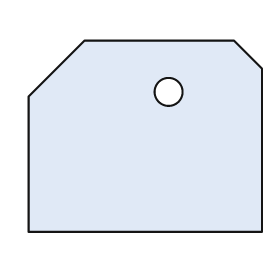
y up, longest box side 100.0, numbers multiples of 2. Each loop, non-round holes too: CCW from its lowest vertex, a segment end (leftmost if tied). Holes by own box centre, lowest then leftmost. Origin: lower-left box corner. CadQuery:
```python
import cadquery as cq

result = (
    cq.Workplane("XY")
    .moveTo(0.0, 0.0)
    .lineTo(100.0, 0.0)
    .lineTo(100.0, 70.0)
    .lineTo(88.0, 82.0)
    .lineTo(24.0, 82.0)
    .lineTo(0.0, 58.0)
    .close()
    .moveTo(60.0, 60.0)
    .circle(6.0)
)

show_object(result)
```